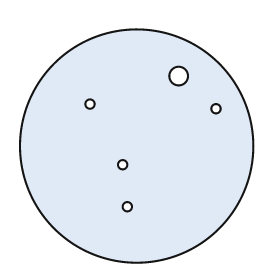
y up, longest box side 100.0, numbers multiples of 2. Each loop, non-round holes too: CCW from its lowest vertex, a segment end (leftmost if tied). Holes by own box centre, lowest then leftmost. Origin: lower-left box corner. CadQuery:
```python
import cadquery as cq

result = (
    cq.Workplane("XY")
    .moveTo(50.0, 50.0)
    .circle(50.0)
    .moveTo(46.0, 24.0)
    .circle(2.0)
    .moveTo(44.0, 42.0)
    .circle(2.0)
    .moveTo(84.0, 66.0)
    .circle(2.0)
    .moveTo(30.0, 68.0)
    .circle(2.0)
    .moveTo(68.0, 80.0)
    .circle(4.0)
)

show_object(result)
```